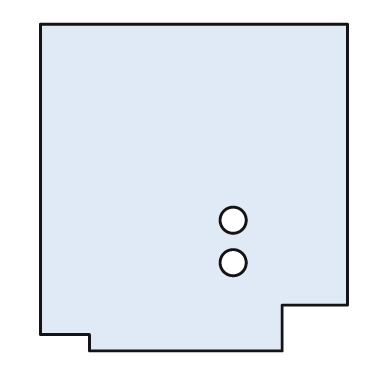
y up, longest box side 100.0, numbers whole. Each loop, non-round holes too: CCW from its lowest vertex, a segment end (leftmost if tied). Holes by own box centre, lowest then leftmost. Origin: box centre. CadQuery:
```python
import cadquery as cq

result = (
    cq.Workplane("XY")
    .moveTo(-32.0, -50.0)
    .lineTo(27.0, -50.0)
    .lineTo(27.0, -36.0)
    .lineTo(47.0, -36.0)
    .lineTo(47.0, 50.0)
    .lineTo(-47.0, 50.0)
    .lineTo(-47.0, -45.0)
    .lineTo(-32.0, -45.0)
    .close()
    .moveTo(12.0, -23.0)
    .circle(4.0)
    .moveTo(12.0, -10.0)
    .circle(4.0)
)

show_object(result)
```